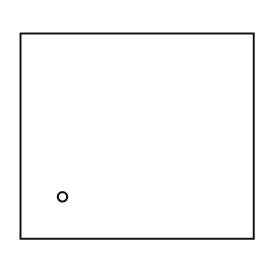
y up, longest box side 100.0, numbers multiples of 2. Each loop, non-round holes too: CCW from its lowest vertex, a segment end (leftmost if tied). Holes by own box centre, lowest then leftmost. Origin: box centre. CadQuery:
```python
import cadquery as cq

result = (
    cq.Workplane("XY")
    .moveTo(-50.0, -44.0)
    .lineTo(50.0, -44.0)
    .lineTo(50.0, 44.0)
    .lineTo(-50.0, 44.0)
    .close()
    .moveTo(-32.0, -26.0)
    .circle(2.0)
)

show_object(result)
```